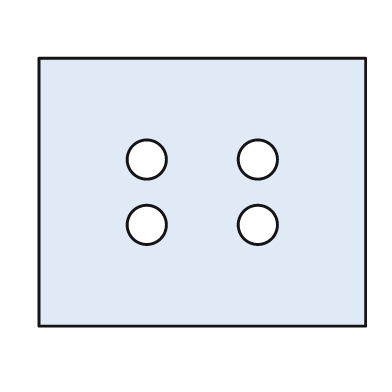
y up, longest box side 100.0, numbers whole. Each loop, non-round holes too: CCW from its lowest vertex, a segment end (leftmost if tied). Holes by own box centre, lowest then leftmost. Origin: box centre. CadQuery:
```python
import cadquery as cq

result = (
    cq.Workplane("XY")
    .moveTo(-50.0, -41.0)
    .lineTo(50.0, -41.0)
    .lineTo(50.0, 41.0)
    .lineTo(-50.0, 41.0)
    .close()
    .moveTo(-17.0, -10.0)
    .circle(6.0)
    .moveTo(17.0, -10.0)
    .circle(6.0)
    .moveTo(-17.0, 10.0)
    .circle(6.0)
    .moveTo(17.0, 10.0)
    .circle(6.0)
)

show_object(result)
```